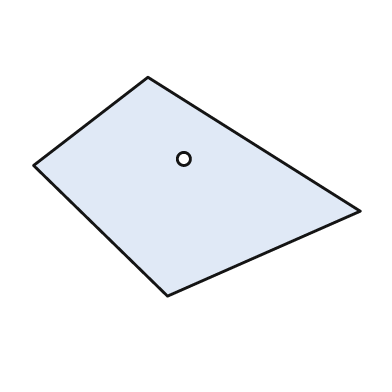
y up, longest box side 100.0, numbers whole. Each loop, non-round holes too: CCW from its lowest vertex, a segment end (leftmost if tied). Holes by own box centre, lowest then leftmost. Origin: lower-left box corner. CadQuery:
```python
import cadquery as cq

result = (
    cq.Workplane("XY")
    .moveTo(41.0, 0.0)
    .lineTo(100.0, 26.0)
    .lineTo(35.0, 67.0)
    .lineTo(0.0, 40.0)
    .close()
    .moveTo(46.0, 42.0)
    .circle(2.0)
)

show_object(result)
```